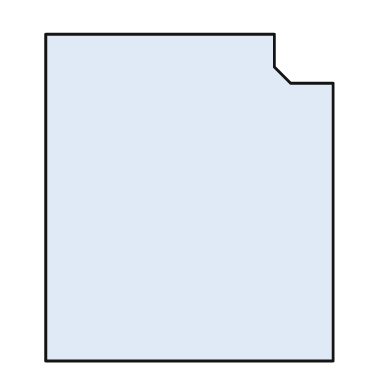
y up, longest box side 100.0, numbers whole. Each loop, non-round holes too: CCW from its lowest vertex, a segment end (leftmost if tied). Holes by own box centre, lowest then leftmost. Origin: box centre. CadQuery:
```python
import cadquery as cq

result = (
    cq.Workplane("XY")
    .moveTo(-44.0, -50.0)
    .lineTo(44.0, -50.0)
    .lineTo(44.0, 35.0)
    .lineTo(31.0, 35.0)
    .lineTo(26.0, 40.0)
    .lineTo(26.0, 50.0)
    .lineTo(-44.0, 50.0)
    .close()
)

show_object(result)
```